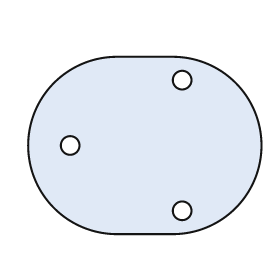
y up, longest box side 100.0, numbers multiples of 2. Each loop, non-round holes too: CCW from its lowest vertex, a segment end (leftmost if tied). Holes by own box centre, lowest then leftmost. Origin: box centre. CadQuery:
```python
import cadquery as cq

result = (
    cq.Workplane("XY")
    .moveTo(-12.0, -38.0)
    .lineTo(12.0, -38.0)
    .threePointArc((50.0, 0.0), (12.0, 38.0))
    .lineTo(-12.0, 38.0)
    .threePointArc((-50.0, 0.0), (-12.0, -38.0))
    .close()
    .moveTo(16.0, -28.0)
    .circle(4.0)
    .moveTo(-32.0, 0.0)
    .circle(4.0)
    .moveTo(16.0, 28.0)
    .circle(4.0)
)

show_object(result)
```